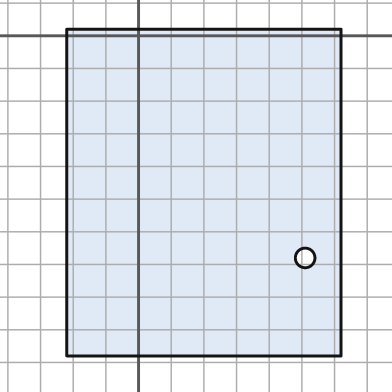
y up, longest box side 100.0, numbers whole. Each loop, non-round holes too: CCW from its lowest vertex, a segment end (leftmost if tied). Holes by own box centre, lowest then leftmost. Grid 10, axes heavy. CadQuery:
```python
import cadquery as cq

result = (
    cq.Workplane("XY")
    .moveTo(-22.0, -98.0)
    .lineTo(62.0, -98.0)
    .lineTo(62.0, 2.0)
    .lineTo(-22.0, 2.0)
    .close()
    .moveTo(51.0, -68.0)
    .circle(3.0)
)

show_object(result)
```